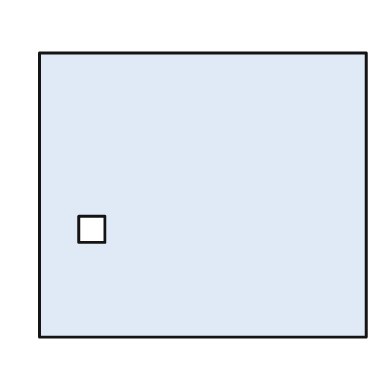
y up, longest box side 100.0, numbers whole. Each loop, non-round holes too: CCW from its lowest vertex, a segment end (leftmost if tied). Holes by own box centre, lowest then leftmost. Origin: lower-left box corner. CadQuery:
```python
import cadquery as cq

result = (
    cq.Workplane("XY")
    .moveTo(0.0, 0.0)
    .lineTo(100.0, 0.0)
    .lineTo(100.0, 87.0)
    .lineTo(0.0, 87.0)
    .close()
    .moveTo(12.0, 29.0)
    .lineTo(20.0, 29.0)
    .lineTo(20.0, 37.0)
    .lineTo(12.0, 37.0)
    .close()
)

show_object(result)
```